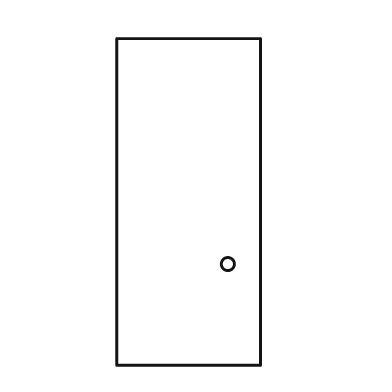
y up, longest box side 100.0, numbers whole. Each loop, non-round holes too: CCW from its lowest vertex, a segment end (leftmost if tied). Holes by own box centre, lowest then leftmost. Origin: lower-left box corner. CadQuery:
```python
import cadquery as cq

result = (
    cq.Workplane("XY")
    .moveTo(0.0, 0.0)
    .lineTo(44.0, 0.0)
    .lineTo(44.0, 100.0)
    .lineTo(0.0, 100.0)
    .close()
    .moveTo(34.0, 31.0)
    .circle(2.0)
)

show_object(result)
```